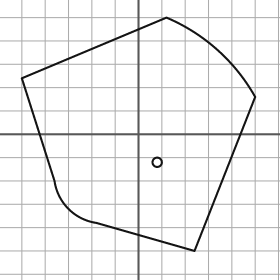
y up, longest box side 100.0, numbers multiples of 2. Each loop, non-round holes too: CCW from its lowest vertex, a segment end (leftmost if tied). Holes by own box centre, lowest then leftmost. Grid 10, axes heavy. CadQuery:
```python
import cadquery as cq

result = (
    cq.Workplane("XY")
    .moveTo(24.0, -50.0)
    .lineTo(50.0, 16.0)
    .threePointArc((34.0, 36.0), (12.0, 50.0))
    .lineTo(-50.0, 24.0)
    .lineTo(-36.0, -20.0)
    .threePointArc((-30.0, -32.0), (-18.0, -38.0))
    .close()
    .moveTo(8.0, -12.0)
    .circle(2.0)
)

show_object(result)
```